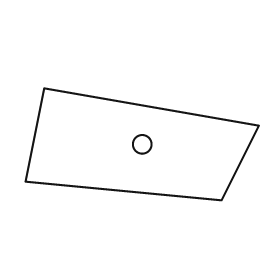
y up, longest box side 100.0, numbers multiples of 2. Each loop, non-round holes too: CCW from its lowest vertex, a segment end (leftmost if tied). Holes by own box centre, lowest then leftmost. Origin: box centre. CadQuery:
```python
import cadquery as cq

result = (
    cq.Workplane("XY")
    .moveTo(34.0, -24.0)
    .lineTo(50.0, 8.0)
    .lineTo(-42.0, 24.0)
    .lineTo(-50.0, -16.0)
    .close()
    .moveTo(0.0, 0.0)
    .circle(4.0)
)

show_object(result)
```